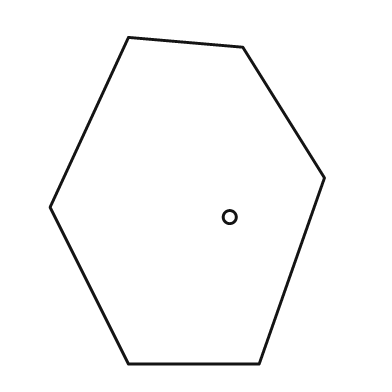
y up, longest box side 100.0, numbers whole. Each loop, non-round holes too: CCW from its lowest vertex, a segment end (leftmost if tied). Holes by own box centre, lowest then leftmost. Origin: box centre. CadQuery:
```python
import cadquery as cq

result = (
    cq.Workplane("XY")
    .moveTo(-18.0, -50.0)
    .lineTo(22.0, -50.0)
    .lineTo(42.0, 7.0)
    .lineTo(17.0, 47.0)
    .lineTo(-18.0, 50.0)
    .lineTo(-42.0, -2.0)
    .close()
    .moveTo(13.0, -5.0)
    .circle(2.0)
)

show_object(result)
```